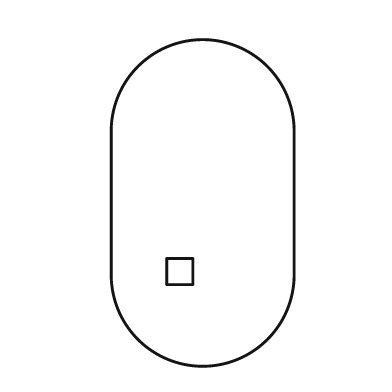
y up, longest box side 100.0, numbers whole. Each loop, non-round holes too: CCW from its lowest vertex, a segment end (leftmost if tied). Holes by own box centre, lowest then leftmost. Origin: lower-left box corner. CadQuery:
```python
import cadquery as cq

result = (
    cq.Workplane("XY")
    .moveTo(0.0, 28.0)
    .threePointArc((28.0, 0.0), (56.0, 28.0))
    .lineTo(56.0, 72.0)
    .threePointArc((28.0, 100.0), (0.0, 72.0))
    .close()
    .moveTo(17.0, 25.0)
    .lineTo(25.0, 25.0)
    .lineTo(25.0, 33.0)
    .lineTo(17.0, 33.0)
    .close()
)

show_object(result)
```